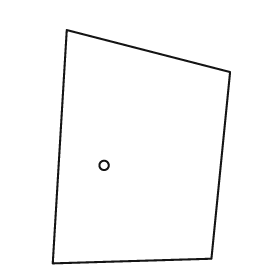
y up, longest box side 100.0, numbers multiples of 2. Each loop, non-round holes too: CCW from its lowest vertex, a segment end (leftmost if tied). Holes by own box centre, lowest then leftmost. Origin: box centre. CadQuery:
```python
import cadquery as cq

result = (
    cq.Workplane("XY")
    .moveTo(-38.0, -50.0)
    .lineTo(30.0, -48.0)
    .lineTo(38.0, 32.0)
    .lineTo(-32.0, 50.0)
    .close()
    .moveTo(-16.0, -8.0)
    .circle(2.0)
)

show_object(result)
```